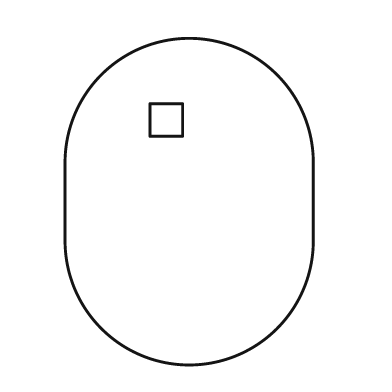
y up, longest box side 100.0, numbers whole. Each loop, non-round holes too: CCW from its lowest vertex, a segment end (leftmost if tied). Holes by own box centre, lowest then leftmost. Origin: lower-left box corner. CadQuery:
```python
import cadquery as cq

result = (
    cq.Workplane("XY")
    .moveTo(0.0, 38.0)
    .threePointArc((38.0, 0.0), (76.0, 38.0))
    .lineTo(76.0, 62.0)
    .threePointArc((38.0, 100.0), (0.0, 62.0))
    .close()
    .moveTo(26.0, 70.0)
    .lineTo(36.0, 70.0)
    .lineTo(36.0, 80.0)
    .lineTo(26.0, 80.0)
    .close()
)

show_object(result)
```